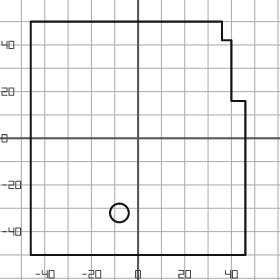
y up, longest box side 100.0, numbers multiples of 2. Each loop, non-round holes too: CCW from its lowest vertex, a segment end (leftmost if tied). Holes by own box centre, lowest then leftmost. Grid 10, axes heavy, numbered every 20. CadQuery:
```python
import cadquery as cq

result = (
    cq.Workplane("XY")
    .moveTo(-46.0, -50.0)
    .lineTo(46.0, -50.0)
    .lineTo(46.0, 16.0)
    .lineTo(40.0, 16.0)
    .lineTo(40.0, 42.0)
    .lineTo(36.0, 42.0)
    .lineTo(36.0, 50.0)
    .lineTo(-46.0, 50.0)
    .close()
    .moveTo(-8.0, -32.0)
    .circle(4.0)
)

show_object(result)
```